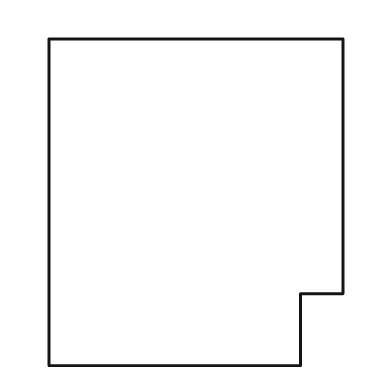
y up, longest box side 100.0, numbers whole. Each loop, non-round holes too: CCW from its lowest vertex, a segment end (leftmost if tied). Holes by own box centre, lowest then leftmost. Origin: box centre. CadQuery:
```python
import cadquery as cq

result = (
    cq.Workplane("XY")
    .moveTo(-45.0, -50.0)
    .lineTo(32.0, -50.0)
    .lineTo(32.0, -28.0)
    .lineTo(45.0, -28.0)
    .lineTo(45.0, 50.0)
    .lineTo(-45.0, 50.0)
    .close()
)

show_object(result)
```